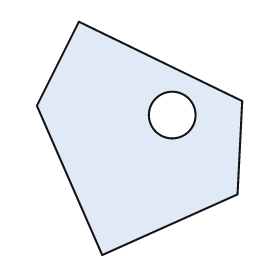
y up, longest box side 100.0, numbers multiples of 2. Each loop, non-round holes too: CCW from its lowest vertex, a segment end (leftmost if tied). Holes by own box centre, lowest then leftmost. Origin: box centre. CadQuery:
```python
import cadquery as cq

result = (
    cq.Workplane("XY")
    .moveTo(-16.0, -50.0)
    .lineTo(42.0, -24.0)
    .lineTo(44.0, 16.0)
    .lineTo(-26.0, 50.0)
    .lineTo(-44.0, 14.0)
    .close()
    .moveTo(14.0, 10.0)
    .circle(10.0)
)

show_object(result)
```